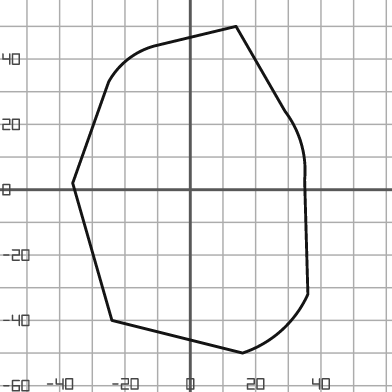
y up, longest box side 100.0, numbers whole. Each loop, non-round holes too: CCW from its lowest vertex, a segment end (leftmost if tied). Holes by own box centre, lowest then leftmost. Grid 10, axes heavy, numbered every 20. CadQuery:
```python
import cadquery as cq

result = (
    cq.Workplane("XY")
    .moveTo(16.0, -50.0)
    .threePointArc((28.0, -43.0), (36.0, -32.0))
    .lineTo(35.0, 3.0)
    .threePointArc((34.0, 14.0), (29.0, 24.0))
    .lineTo(14.0, 50.0)
    .lineTo(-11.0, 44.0)
    .threePointArc((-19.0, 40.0), (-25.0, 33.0))
    .lineTo(-36.0, 2.0)
    .lineTo(-24.0, -40.0)
    .close()
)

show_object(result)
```